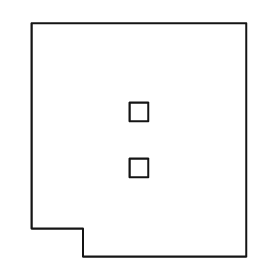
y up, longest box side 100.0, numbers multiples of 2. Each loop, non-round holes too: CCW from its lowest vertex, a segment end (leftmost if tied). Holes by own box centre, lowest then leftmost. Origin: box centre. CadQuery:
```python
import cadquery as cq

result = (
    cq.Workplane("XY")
    .moveTo(-24.0, -50.0)
    .lineTo(46.0, -50.0)
    .lineTo(46.0, 50.0)
    .lineTo(-46.0, 50.0)
    .lineTo(-46.0, -38.0)
    .lineTo(-24.0, -38.0)
    .close()
    .moveTo(-4.0, -16.0)
    .lineTo(4.0, -16.0)
    .lineTo(4.0, -8.0)
    .lineTo(-4.0, -8.0)
    .close()
    .moveTo(-4.0, 8.0)
    .lineTo(4.0, 8.0)
    .lineTo(4.0, 16.0)
    .lineTo(-4.0, 16.0)
    .close()
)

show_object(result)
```